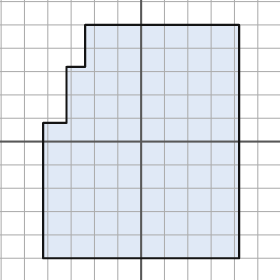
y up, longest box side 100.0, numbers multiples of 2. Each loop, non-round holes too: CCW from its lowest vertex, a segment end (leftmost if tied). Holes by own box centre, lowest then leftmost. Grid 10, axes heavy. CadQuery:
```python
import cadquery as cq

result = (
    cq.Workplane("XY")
    .moveTo(-42.0, -50.0)
    .lineTo(42.0, -50.0)
    .lineTo(42.0, 50.0)
    .lineTo(-24.0, 50.0)
    .lineTo(-24.0, 32.0)
    .lineTo(-32.0, 32.0)
    .lineTo(-32.0, 8.0)
    .lineTo(-42.0, 8.0)
    .close()
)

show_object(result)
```